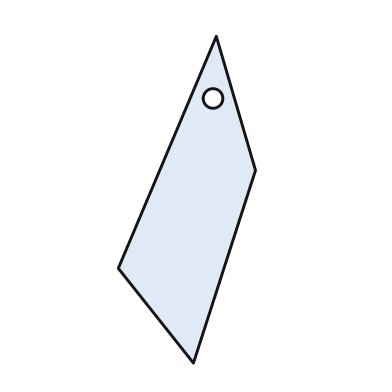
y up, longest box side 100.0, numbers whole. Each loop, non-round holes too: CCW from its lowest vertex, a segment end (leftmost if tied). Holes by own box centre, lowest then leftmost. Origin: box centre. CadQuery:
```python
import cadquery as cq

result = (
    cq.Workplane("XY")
    .moveTo(2.0, -50.0)
    .lineTo(21.0, 9.0)
    .lineTo(9.0, 50.0)
    .lineTo(-21.0, -21.0)
    .close()
    .moveTo(8.0, 31.0)
    .circle(3.0)
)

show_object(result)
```